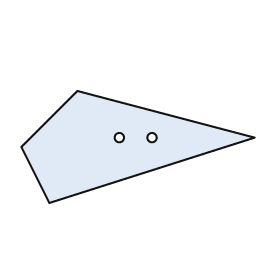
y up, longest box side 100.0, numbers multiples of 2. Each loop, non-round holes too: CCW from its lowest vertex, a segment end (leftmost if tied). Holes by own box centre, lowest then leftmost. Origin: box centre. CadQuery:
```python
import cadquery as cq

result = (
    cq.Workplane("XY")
    .moveTo(-38.0, -24.0)
    .lineTo(50.0, 4.0)
    .lineTo(-26.0, 24.0)
    .lineTo(-50.0, 0.0)
    .close()
    .moveTo(-8.0, 4.0)
    .circle(2.0)
    .moveTo(6.0, 4.0)
    .circle(2.0)
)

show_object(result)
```